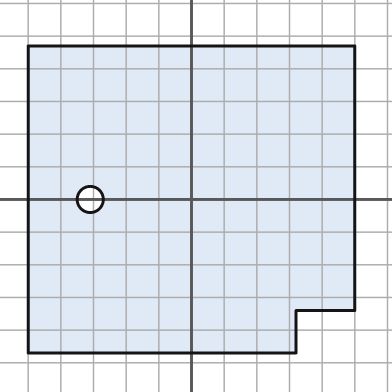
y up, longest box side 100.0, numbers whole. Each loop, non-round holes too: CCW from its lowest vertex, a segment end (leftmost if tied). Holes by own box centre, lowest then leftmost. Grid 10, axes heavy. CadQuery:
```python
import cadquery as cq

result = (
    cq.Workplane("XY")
    .moveTo(-50.0, -47.0)
    .lineTo(32.0, -47.0)
    .lineTo(32.0, -34.0)
    .lineTo(50.0, -34.0)
    .lineTo(50.0, 47.0)
    .lineTo(-50.0, 47.0)
    .close()
    .moveTo(-31.0, 0.0)
    .circle(4.0)
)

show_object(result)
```